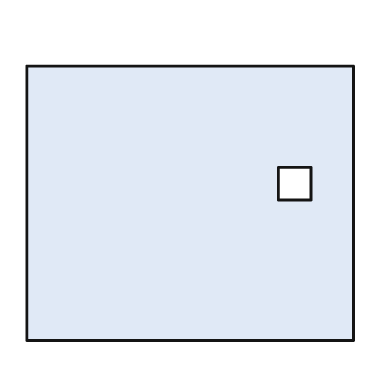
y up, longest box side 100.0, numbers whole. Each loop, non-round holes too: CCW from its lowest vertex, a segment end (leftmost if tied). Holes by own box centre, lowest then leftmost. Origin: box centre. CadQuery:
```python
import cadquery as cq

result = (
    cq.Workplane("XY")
    .moveTo(-50.0, -42.0)
    .lineTo(50.0, -42.0)
    .lineTo(50.0, 42.0)
    .lineTo(-50.0, 42.0)
    .close()
    .moveTo(27.0, 1.0)
    .lineTo(37.0, 1.0)
    .lineTo(37.0, 11.0)
    .lineTo(27.0, 11.0)
    .close()
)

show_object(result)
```